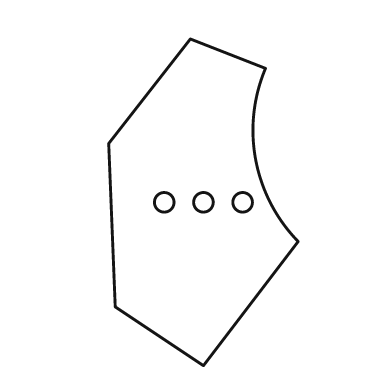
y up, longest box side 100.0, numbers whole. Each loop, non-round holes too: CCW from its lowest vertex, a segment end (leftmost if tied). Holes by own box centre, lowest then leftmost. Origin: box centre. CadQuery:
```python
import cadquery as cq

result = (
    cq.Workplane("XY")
    .moveTo(0.0, -50.0)
    .lineTo(29.0, -12.0)
    .threePointArc((16.0, 13.0), (19.0, 41.0))
    .lineTo(-4.0, 50.0)
    .lineTo(-29.0, 18.0)
    .lineTo(-27.0, -32.0)
    .close()
    .moveTo(-12.0, 0.0)
    .circle(3.0)
    .moveTo(0.0, 0.0)
    .circle(3.0)
    .moveTo(12.0, 0.0)
    .circle(3.0)
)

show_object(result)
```